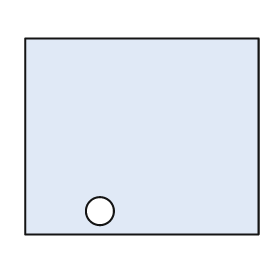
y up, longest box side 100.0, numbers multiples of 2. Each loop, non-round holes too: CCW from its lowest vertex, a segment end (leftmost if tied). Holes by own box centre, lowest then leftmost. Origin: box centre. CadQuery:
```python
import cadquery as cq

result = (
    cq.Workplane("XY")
    .moveTo(-50.0, -42.0)
    .lineTo(50.0, -42.0)
    .lineTo(50.0, 42.0)
    .lineTo(-50.0, 42.0)
    .close()
    .moveTo(-18.0, -32.0)
    .circle(6.0)
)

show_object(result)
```